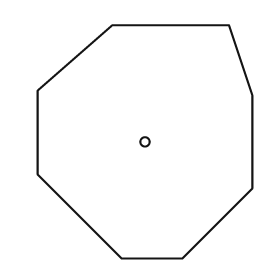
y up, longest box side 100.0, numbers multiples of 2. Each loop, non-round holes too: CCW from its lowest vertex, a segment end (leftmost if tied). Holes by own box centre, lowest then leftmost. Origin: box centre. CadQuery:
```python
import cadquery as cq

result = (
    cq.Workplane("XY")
    .moveTo(-10.0, -50.0)
    .lineTo(16.0, -50.0)
    .lineTo(46.0, -20.0)
    .lineTo(46.0, 20.0)
    .lineTo(36.0, 50.0)
    .lineTo(-14.0, 50.0)
    .lineTo(-46.0, 22.0)
    .lineTo(-46.0, -14.0)
    .close()
    .moveTo(0.0, 0.0)
    .circle(2.0)
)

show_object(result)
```